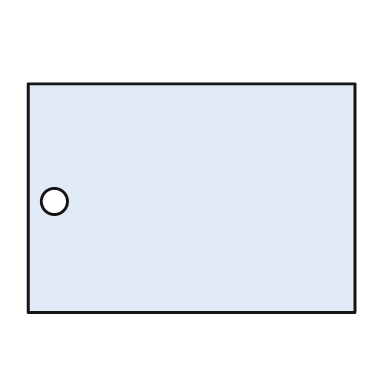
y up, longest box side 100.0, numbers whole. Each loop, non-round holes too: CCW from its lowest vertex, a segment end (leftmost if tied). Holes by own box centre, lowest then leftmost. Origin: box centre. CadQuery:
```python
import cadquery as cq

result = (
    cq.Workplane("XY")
    .moveTo(-50.0, -35.0)
    .lineTo(50.0, -35.0)
    .lineTo(50.0, 35.0)
    .lineTo(-50.0, 35.0)
    .close()
    .moveTo(-42.0, -1.0)
    .circle(4.0)
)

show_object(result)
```